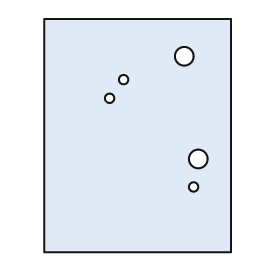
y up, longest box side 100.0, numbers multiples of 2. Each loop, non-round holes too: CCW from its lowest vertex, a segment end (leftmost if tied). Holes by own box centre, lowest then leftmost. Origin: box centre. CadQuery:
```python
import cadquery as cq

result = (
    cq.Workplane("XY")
    .moveTo(-40.0, -50.0)
    .lineTo(40.0, -50.0)
    .lineTo(40.0, 50.0)
    .lineTo(-40.0, 50.0)
    .close()
    .moveTo(24.0, -22.0)
    .circle(2.0)
    .moveTo(26.0, -10.0)
    .circle(4.0)
    .moveTo(-12.0, 16.0)
    .circle(2.0)
    .moveTo(-6.0, 24.0)
    .circle(2.0)
    .moveTo(20.0, 34.0)
    .circle(4.0)
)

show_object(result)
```